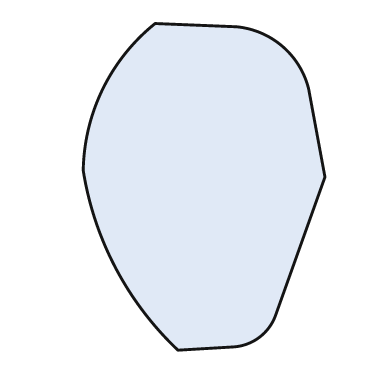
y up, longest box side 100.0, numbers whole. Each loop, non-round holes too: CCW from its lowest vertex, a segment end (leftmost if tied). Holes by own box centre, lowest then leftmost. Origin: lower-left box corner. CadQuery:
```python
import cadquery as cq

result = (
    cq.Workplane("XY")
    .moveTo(29.0, 0.0)
    .lineTo(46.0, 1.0)
    .threePointArc((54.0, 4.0), (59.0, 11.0))
    .lineTo(74.0, 53.0)
    .lineTo(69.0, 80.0)
    .threePointArc((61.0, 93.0), (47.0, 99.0))
    .lineTo(22.0, 100.0)
    .threePointArc((6.0, 80.0), (0.0, 55.0))
    .threePointArc((10.0, 25.0), (29.0, 0.0))
    .close()
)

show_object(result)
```